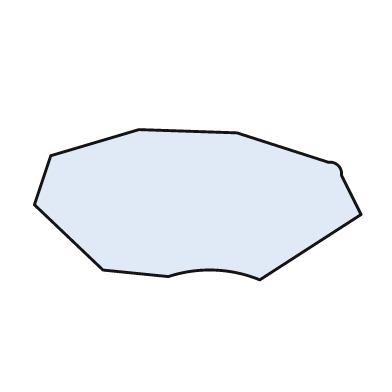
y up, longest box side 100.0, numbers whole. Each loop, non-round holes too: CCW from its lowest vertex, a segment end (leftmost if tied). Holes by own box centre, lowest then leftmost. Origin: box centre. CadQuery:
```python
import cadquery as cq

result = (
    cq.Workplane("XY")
    .moveTo(19.0, -23.0)
    .lineTo(50.0, -3.0)
    .lineTo(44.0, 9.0)
    .threePointArc((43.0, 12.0), (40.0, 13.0))
    .lineTo(12.0, 22.0)
    .lineTo(-18.0, 23.0)
    .lineTo(-45.0, 15.0)
    .lineTo(-50.0, 0.0)
    .lineTo(-29.0, -20.0)
    .lineTo(-9.0, -22.0)
    .threePointArc((5.0, -20.0), (19.0, -23.0))
    .close()
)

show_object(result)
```